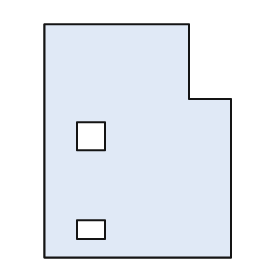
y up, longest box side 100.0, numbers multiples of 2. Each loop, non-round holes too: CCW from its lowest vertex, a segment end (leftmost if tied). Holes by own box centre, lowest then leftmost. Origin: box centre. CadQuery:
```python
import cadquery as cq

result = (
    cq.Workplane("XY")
    .moveTo(-40.0, -50.0)
    .lineTo(40.0, -50.0)
    .lineTo(40.0, 18.0)
    .lineTo(22.0, 18.0)
    .lineTo(22.0, 50.0)
    .lineTo(-40.0, 50.0)
    .close()
    .moveTo(-26.0, -42.0)
    .lineTo(-14.0, -42.0)
    .lineTo(-14.0, -34.0)
    .lineTo(-26.0, -34.0)
    .close()
    .moveTo(-26.0, -4.0)
    .lineTo(-14.0, -4.0)
    .lineTo(-14.0, 8.0)
    .lineTo(-26.0, 8.0)
    .close()
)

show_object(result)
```